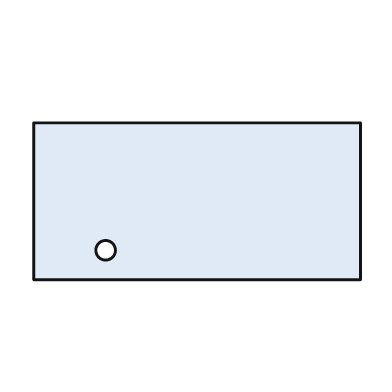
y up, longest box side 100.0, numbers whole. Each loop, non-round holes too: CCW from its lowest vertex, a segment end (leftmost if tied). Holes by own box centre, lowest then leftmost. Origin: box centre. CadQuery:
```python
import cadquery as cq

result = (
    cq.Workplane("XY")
    .moveTo(-50.0, -24.0)
    .lineTo(50.0, -24.0)
    .lineTo(50.0, 24.0)
    .lineTo(-50.0, 24.0)
    .close()
    .moveTo(-28.0, -15.0)
    .circle(3.0)
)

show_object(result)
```